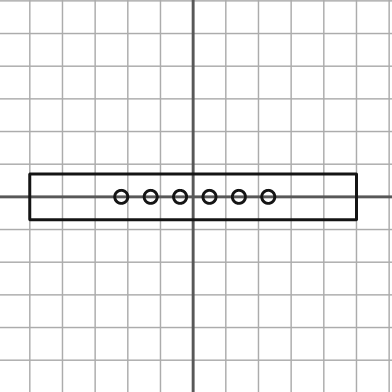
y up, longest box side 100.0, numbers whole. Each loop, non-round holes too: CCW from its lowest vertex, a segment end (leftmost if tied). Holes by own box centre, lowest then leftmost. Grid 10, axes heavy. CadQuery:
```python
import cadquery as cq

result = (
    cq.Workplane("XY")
    .moveTo(-50.0, -7.0)
    .lineTo(50.0, -7.0)
    .lineTo(50.0, 7.0)
    .lineTo(-50.0, 7.0)
    .close()
    .moveTo(-22.0, 0.0)
    .circle(2.0)
    .moveTo(-13.0, 0.0)
    .circle(2.0)
    .moveTo(-4.0, 0.0)
    .circle(2.0)
    .moveTo(5.0, 0.0)
    .circle(2.0)
    .moveTo(14.0, 0.0)
    .circle(2.0)
    .moveTo(23.0, 0.0)
    .circle(2.0)
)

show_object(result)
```